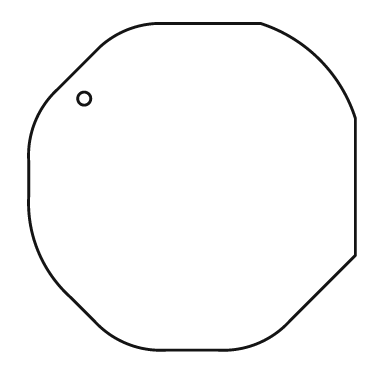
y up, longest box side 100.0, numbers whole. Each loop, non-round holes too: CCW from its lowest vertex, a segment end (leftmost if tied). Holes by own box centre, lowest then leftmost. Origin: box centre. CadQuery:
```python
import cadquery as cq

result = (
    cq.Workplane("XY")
    .moveTo(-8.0, -50.0)
    .lineTo(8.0, -50.0)
    .threePointArc((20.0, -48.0), (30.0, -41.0))
    .lineTo(50.0, -21.0)
    .lineTo(50.0, 21.0)
    .threePointArc((39.0, 39.0), (21.0, 50.0))
    .lineTo(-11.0, 50.0)
    .threePointArc((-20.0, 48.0), (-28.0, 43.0))
    .lineTo(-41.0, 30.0)
    .threePointArc((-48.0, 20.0), (-50.0, 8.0))
    .lineTo(-50.0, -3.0)
    .threePointArc((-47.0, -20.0), (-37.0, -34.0))
    .lineTo(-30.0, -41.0)
    .threePointArc((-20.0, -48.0), (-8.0, -50.0))
    .close()
    .moveTo(-33.0, 27.0)
    .circle(2.0)
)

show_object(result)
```